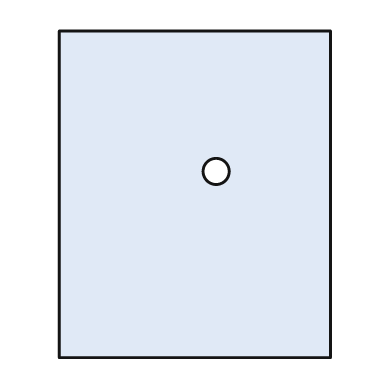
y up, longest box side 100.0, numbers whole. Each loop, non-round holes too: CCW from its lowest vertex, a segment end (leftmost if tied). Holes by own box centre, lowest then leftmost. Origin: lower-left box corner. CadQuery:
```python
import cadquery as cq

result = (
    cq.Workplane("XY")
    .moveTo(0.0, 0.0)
    .lineTo(83.0, 0.0)
    .lineTo(83.0, 100.0)
    .lineTo(0.0, 100.0)
    .close()
    .moveTo(48.0, 57.0)
    .circle(4.0)
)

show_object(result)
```